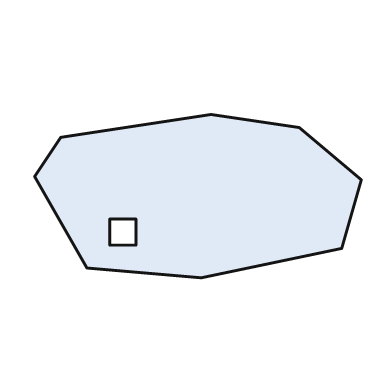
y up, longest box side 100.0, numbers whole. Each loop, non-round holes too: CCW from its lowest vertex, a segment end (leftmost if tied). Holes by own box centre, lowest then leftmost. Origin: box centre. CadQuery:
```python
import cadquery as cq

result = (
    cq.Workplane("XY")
    .moveTo(1.0, -25.0)
    .lineTo(44.0, -16.0)
    .lineTo(50.0, 5.0)
    .lineTo(31.0, 21.0)
    .lineTo(4.0, 25.0)
    .lineTo(-42.0, 18.0)
    .lineTo(-50.0, 6.0)
    .lineTo(-34.0, -22.0)
    .close()
    .moveTo(-27.0, -15.0)
    .lineTo(-19.0, -15.0)
    .lineTo(-19.0, -7.0)
    .lineTo(-27.0, -7.0)
    .close()
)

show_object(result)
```